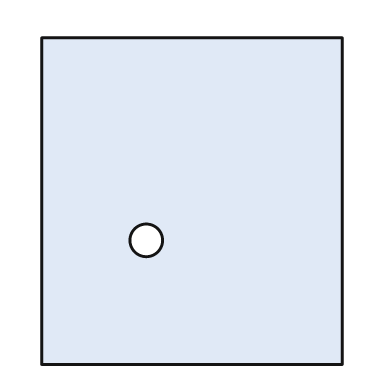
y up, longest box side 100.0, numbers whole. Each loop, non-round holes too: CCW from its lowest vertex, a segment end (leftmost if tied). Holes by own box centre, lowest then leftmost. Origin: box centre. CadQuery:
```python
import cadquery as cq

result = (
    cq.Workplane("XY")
    .moveTo(-46.0, -50.0)
    .lineTo(46.0, -50.0)
    .lineTo(46.0, 50.0)
    .lineTo(-46.0, 50.0)
    .close()
    .moveTo(-14.0, -12.0)
    .circle(5.0)
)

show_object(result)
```